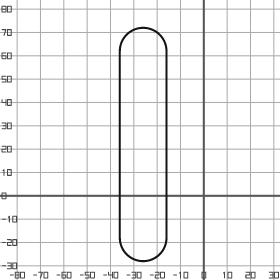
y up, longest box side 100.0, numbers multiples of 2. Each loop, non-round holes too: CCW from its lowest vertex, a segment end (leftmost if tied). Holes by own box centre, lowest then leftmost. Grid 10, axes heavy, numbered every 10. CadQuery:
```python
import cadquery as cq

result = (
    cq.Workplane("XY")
    .moveTo(-36.0, -18.0)
    .threePointArc((-26.0, -28.0), (-16.0, -18.0))
    .lineTo(-16.0, 62.0)
    .threePointArc((-26.0, 72.0), (-36.0, 62.0))
    .close()
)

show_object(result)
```